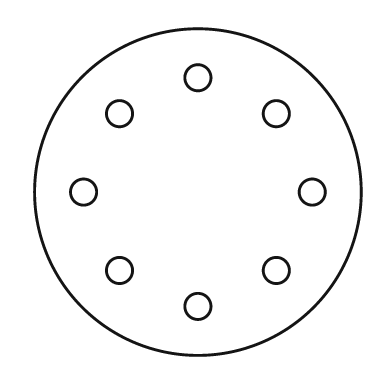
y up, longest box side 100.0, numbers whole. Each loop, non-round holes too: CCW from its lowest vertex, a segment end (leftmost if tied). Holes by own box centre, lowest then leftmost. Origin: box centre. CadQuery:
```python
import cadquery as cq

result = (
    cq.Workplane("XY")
    .moveTo(0.0, 0.0)
    .circle(50.0)
    .moveTo(0.0, -35.0)
    .circle(4.0)
    .moveTo(-24.0, -24.0)
    .circle(4.0)
    .moveTo(24.0, -24.0)
    .circle(4.0)
    .moveTo(-35.0, 0.0)
    .circle(4.0)
    .moveTo(35.0, 0.0)
    .circle(4.0)
    .moveTo(-24.0, 24.0)
    .circle(4.0)
    .moveTo(24.0, 24.0)
    .circle(4.0)
    .moveTo(0.0, 35.0)
    .circle(4.0)
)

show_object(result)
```